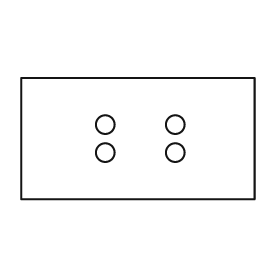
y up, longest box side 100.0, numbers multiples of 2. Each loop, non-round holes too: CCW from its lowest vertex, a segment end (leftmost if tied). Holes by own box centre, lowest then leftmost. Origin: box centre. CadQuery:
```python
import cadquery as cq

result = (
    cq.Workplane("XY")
    .moveTo(-50.0, -26.0)
    .lineTo(50.0, -26.0)
    .lineTo(50.0, 26.0)
    .lineTo(-50.0, 26.0)
    .close()
    .moveTo(-14.0, -6.0)
    .circle(4.0)
    .moveTo(16.0, -6.0)
    .circle(4.0)
    .moveTo(-14.0, 6.0)
    .circle(4.0)
    .moveTo(16.0, 6.0)
    .circle(4.0)
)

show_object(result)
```